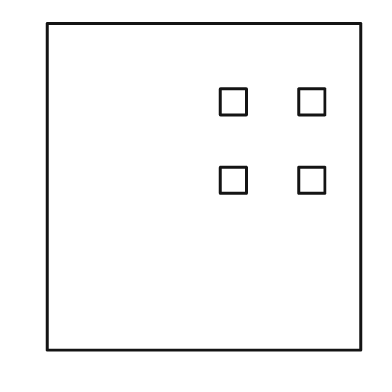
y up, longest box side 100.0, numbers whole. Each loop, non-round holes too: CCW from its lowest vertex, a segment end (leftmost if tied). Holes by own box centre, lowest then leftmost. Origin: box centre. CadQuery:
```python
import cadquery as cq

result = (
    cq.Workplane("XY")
    .moveTo(-48.0, -50.0)
    .lineTo(48.0, -50.0)
    .lineTo(48.0, 50.0)
    .lineTo(-48.0, 50.0)
    .close()
    .moveTo(5.0, -2.0)
    .lineTo(13.0, -2.0)
    .lineTo(13.0, 6.0)
    .lineTo(5.0, 6.0)
    .close()
    .moveTo(29.0, -2.0)
    .lineTo(37.0, -2.0)
    .lineTo(37.0, 6.0)
    .lineTo(29.0, 6.0)
    .close()
    .moveTo(5.0, 22.0)
    .lineTo(13.0, 22.0)
    .lineTo(13.0, 30.0)
    .lineTo(5.0, 30.0)
    .close()
    .moveTo(29.0, 22.0)
    .lineTo(37.0, 22.0)
    .lineTo(37.0, 30.0)
    .lineTo(29.0, 30.0)
    .close()
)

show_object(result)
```